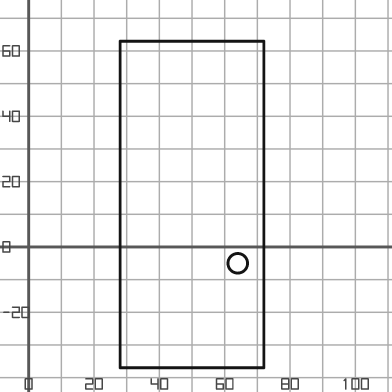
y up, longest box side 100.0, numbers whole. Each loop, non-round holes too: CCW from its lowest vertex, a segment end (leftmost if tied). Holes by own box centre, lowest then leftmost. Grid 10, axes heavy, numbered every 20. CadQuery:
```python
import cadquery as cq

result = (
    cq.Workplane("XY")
    .moveTo(28.0, -37.0)
    .lineTo(72.0, -37.0)
    .lineTo(72.0, 63.0)
    .lineTo(28.0, 63.0)
    .close()
    .moveTo(64.0, -5.0)
    .circle(3.0)
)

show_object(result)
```